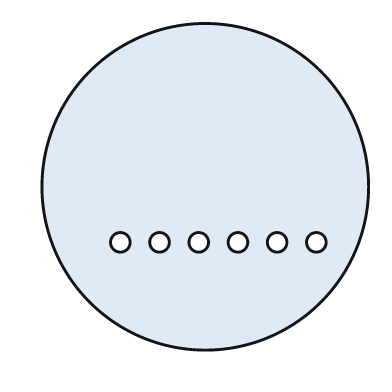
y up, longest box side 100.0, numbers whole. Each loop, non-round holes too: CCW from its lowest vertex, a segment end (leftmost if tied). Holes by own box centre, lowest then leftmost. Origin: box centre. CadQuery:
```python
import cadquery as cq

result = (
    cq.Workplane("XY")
    .moveTo(0.0, 0.0)
    .circle(50.0)
    .moveTo(-26.0, -17.0)
    .circle(3.0)
    .moveTo(-14.0, -17.0)
    .circle(3.0)
    .moveTo(-2.0, -17.0)
    .circle(3.0)
    .moveTo(10.0, -17.0)
    .circle(3.0)
    .moveTo(22.0, -17.0)
    .circle(3.0)
    .moveTo(34.0, -17.0)
    .circle(3.0)
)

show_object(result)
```